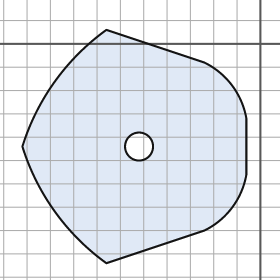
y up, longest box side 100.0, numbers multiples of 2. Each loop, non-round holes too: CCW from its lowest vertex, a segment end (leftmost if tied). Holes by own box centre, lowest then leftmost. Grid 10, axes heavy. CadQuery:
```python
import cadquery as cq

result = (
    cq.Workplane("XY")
    .moveTo(-66.0, -94.0)
    .lineTo(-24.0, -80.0)
    .threePointArc((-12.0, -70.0), (-6.0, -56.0))
    .lineTo(-6.0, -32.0)
    .threePointArc((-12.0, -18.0), (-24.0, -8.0))
    .lineTo(-66.0, 6.0)
    .threePointArc((-88.0, -16.0), (-102.0, -44.0))
    .threePointArc((-88.0, -72.0), (-66.0, -94.0))
    .close()
    .moveTo(-52.0, -44.0)
    .circle(6.0)
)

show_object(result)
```